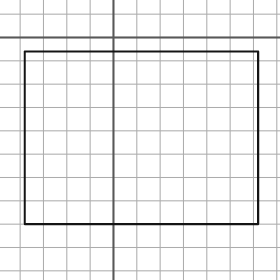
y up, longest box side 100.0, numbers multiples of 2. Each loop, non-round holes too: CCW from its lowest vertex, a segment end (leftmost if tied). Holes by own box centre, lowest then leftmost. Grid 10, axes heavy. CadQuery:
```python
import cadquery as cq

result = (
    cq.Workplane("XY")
    .moveTo(-38.0, -80.0)
    .lineTo(62.0, -80.0)
    .lineTo(62.0, -6.0)
    .lineTo(-38.0, -6.0)
    .close()
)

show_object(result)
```